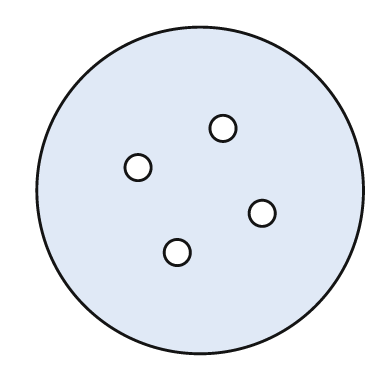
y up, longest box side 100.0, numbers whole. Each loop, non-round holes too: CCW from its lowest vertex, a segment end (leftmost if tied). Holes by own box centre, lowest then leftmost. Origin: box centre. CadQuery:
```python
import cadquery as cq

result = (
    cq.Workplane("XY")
    .moveTo(0.0, 0.0)
    .circle(50.0)
    .moveTo(-7.0, -19.0)
    .circle(4.0)
    .moveTo(19.0, -7.0)
    .circle(4.0)
    .moveTo(-19.0, 7.0)
    .circle(4.0)
    .moveTo(7.0, 19.0)
    .circle(4.0)
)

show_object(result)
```